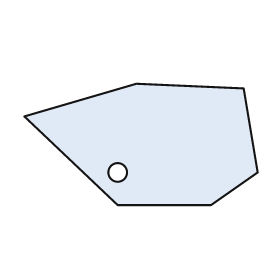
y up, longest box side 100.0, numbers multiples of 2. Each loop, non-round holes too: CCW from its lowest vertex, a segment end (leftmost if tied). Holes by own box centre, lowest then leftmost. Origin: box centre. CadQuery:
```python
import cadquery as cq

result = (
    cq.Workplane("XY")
    .moveTo(-10.0, -26.0)
    .lineTo(30.0, -26.0)
    .lineTo(50.0, -12.0)
    .lineTo(44.0, 24.0)
    .lineTo(-2.0, 26.0)
    .lineTo(-50.0, 12.0)
    .close()
    .moveTo(-10.0, -12.0)
    .circle(4.0)
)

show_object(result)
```